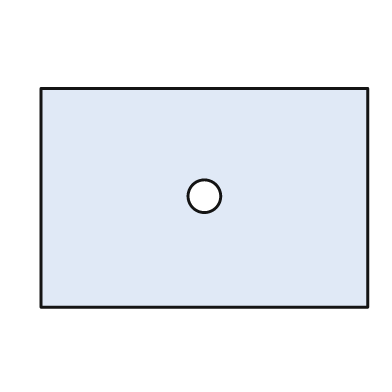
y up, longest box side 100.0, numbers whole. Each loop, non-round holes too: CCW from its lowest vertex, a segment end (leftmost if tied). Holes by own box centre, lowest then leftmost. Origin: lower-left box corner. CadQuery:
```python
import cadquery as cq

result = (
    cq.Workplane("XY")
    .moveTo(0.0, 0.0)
    .lineTo(100.0, 0.0)
    .lineTo(100.0, 67.0)
    .lineTo(0.0, 67.0)
    .close()
    .moveTo(50.0, 34.0)
    .circle(5.0)
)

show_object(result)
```